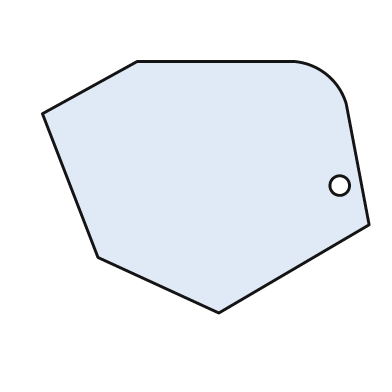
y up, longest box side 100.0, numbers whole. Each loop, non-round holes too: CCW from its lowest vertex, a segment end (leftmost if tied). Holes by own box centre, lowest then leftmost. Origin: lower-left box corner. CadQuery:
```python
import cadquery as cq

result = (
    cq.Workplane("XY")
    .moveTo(54.0, 0.0)
    .lineTo(100.0, 27.0)
    .lineTo(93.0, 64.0)
    .threePointArc((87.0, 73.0), (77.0, 77.0))
    .lineTo(29.0, 77.0)
    .lineTo(0.0, 61.0)
    .lineTo(17.0, 17.0)
    .close()
    .moveTo(91.0, 39.0)
    .circle(3.0)
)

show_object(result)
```